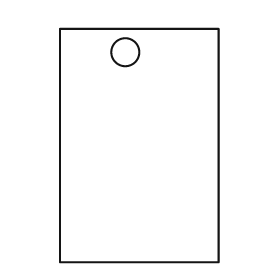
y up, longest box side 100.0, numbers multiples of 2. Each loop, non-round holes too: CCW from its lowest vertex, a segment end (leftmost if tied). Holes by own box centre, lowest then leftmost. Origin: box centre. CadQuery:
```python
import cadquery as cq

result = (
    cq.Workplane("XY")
    .moveTo(-34.0, -50.0)
    .lineTo(34.0, -50.0)
    .lineTo(34.0, 50.0)
    .lineTo(-34.0, 50.0)
    .close()
    .moveTo(-6.0, 40.0)
    .circle(6.0)
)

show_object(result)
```